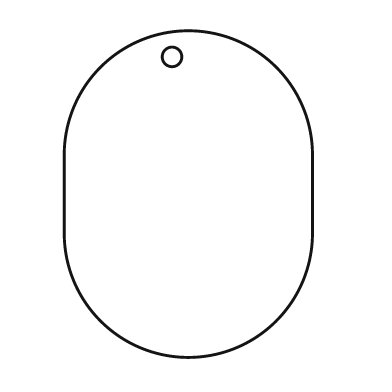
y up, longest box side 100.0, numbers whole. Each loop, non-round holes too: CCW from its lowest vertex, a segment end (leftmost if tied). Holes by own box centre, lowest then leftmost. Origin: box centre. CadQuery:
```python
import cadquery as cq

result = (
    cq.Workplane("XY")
    .moveTo(-38.0, -12.0)
    .threePointArc((0.0, -50.0), (38.0, -12.0))
    .lineTo(38.0, 12.0)
    .threePointArc((0.0, 50.0), (-38.0, 12.0))
    .close()
    .moveTo(-5.0, 42.0)
    .circle(3.0)
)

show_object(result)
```